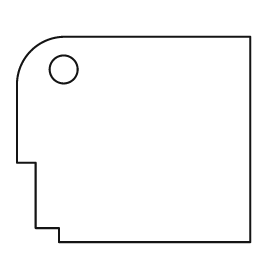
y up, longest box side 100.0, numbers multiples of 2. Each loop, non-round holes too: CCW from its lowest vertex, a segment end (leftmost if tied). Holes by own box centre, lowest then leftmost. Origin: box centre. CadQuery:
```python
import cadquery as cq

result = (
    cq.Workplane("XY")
    .moveTo(-32.0, -44.0)
    .lineTo(50.0, -44.0)
    .lineTo(50.0, 44.0)
    .lineTo(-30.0, 44.0)
    .threePointArc((-44.0, 38.0), (-50.0, 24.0))
    .lineTo(-50.0, -10.0)
    .lineTo(-42.0, -10.0)
    .lineTo(-42.0, -38.0)
    .lineTo(-32.0, -38.0)
    .close()
    .moveTo(-30.0, 30.0)
    .circle(6.0)
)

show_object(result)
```